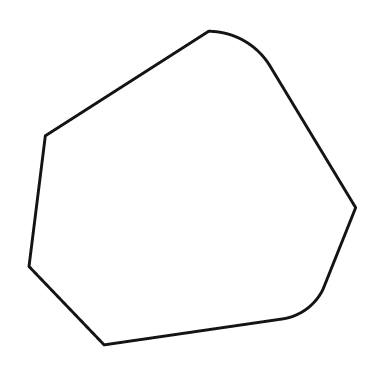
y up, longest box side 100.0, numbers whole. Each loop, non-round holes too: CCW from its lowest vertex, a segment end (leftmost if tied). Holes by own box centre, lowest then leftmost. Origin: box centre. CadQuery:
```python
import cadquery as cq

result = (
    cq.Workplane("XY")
    .moveTo(-27.0, -48.0)
    .lineTo(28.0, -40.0)
    .threePointArc((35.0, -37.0), (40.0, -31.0))
    .lineTo(50.0, -6.0)
    .lineTo(24.0, 37.0)
    .threePointArc((16.0, 45.0), (5.0, 48.0))
    .lineTo(-45.0, 16.0)
    .lineTo(-50.0, -24.0)
    .close()
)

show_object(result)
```